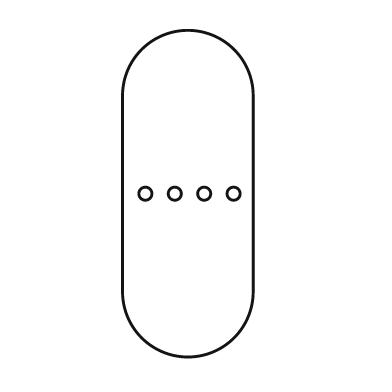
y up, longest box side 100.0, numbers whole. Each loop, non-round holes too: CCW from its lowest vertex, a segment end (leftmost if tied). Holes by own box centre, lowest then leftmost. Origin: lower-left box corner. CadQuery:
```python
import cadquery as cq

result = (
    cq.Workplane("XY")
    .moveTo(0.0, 20.0)
    .threePointArc((20.0, 0.0), (40.0, 20.0))
    .lineTo(40.0, 80.0)
    .threePointArc((20.0, 100.0), (0.0, 80.0))
    .close()
    .moveTo(7.0, 50.0)
    .circle(2.0)
    .moveTo(16.0, 50.0)
    .circle(2.0)
    .moveTo(25.0, 50.0)
    .circle(2.0)
    .moveTo(34.0, 50.0)
    .circle(2.0)
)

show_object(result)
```